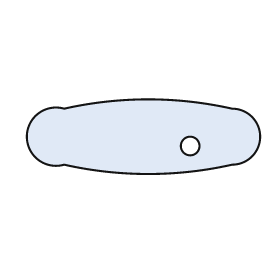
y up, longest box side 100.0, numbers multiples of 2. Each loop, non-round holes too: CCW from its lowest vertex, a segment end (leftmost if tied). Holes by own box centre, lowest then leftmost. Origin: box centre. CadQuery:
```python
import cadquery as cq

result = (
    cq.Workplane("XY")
    .moveTo(-34.0, -12.0)
    .threePointArc((2.0, -16.0), (38.0, -12.0))
    .threePointArc((50.0, 0.0), (38.0, 12.0))
    .threePointArc((2.0, 16.0), (-34.0, 12.0))
    .threePointArc((-50.0, 0.0), (-34.0, -12.0))
    .close()
    .moveTo(20.0, -4.0)
    .circle(4.0)
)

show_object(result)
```